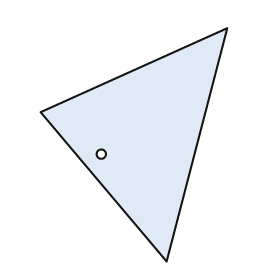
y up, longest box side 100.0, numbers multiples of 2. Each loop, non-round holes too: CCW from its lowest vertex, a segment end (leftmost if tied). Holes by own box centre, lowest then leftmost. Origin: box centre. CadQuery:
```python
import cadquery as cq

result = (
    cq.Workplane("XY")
    .moveTo(14.0, -50.0)
    .lineTo(40.0, 50.0)
    .lineTo(-40.0, 14.0)
    .close()
    .moveTo(-14.0, -4.0)
    .circle(2.0)
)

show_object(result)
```